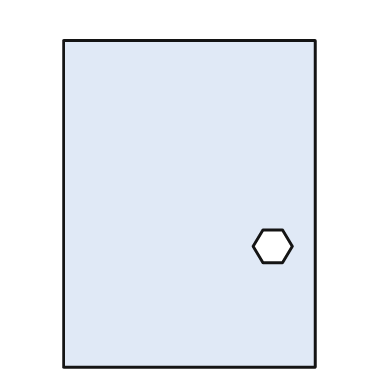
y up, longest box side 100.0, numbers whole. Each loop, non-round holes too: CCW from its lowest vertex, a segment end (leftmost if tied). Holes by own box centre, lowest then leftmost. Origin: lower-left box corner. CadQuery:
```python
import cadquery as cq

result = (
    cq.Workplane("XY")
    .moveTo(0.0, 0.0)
    .lineTo(77.0, 0.0)
    .lineTo(77.0, 100.0)
    .lineTo(0.0, 100.0)
    .close()
    .moveTo(61.0, 32.0)
    .lineTo(67.0, 32.0)
    .lineTo(70.0, 37.0)
    .lineTo(67.0, 42.0)
    .lineTo(61.0, 42.0)
    .lineTo(58.0, 37.0)
    .close()
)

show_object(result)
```